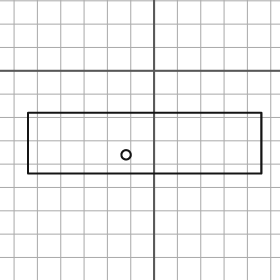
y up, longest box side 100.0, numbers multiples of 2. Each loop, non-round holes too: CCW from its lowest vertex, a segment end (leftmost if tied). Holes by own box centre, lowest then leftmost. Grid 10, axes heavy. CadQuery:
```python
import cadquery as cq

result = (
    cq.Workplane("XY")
    .moveTo(-54.0, -44.0)
    .lineTo(46.0, -44.0)
    .lineTo(46.0, -18.0)
    .lineTo(-54.0, -18.0)
    .close()
    .moveTo(-12.0, -36.0)
    .circle(2.0)
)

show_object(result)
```